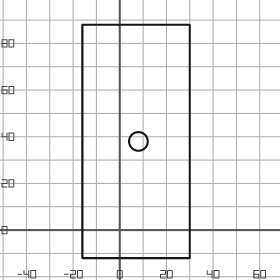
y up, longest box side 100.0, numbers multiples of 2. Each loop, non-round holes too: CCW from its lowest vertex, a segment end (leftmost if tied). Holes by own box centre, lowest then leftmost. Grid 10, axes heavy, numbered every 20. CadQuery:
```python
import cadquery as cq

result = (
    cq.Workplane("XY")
    .moveTo(-16.0, -12.0)
    .lineTo(30.0, -12.0)
    .lineTo(30.0, 88.0)
    .lineTo(-16.0, 88.0)
    .close()
    .moveTo(8.0, 38.0)
    .circle(4.0)
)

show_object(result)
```